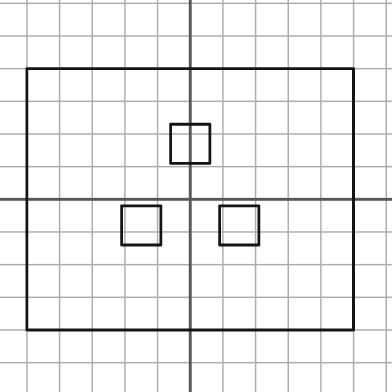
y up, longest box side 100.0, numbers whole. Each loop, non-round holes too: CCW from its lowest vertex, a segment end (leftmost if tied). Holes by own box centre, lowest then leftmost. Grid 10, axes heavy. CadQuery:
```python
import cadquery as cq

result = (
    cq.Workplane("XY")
    .moveTo(-50.0, -40.0)
    .lineTo(50.0, -40.0)
    .lineTo(50.0, 40.0)
    .lineTo(-50.0, 40.0)
    .close()
    .moveTo(-21.0, -14.0)
    .lineTo(-9.0, -14.0)
    .lineTo(-9.0, -2.0)
    .lineTo(-21.0, -2.0)
    .close()
    .moveTo(9.0, -14.0)
    .lineTo(21.0, -14.0)
    .lineTo(21.0, -2.0)
    .lineTo(9.0, -2.0)
    .close()
    .moveTo(-6.0, 11.0)
    .lineTo(6.0, 11.0)
    .lineTo(6.0, 23.0)
    .lineTo(-6.0, 23.0)
    .close()
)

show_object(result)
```